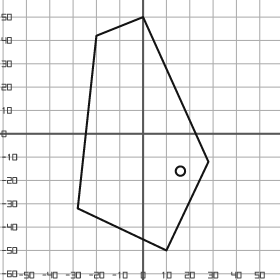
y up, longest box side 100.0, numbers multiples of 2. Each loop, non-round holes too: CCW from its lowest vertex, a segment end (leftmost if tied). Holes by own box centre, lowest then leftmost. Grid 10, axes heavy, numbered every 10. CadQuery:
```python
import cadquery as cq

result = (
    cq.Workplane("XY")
    .moveTo(10.0, -50.0)
    .lineTo(28.0, -12.0)
    .lineTo(0.0, 50.0)
    .lineTo(-20.0, 42.0)
    .lineTo(-28.0, -32.0)
    .close()
    .moveTo(16.0, -16.0)
    .circle(2.0)
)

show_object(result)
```